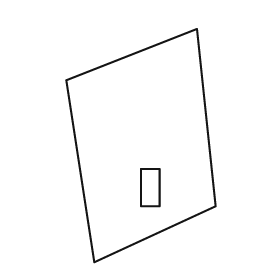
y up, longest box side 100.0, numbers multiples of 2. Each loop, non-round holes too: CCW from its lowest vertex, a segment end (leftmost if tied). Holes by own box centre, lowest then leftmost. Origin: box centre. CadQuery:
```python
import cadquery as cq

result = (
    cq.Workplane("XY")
    .moveTo(-20.0, -50.0)
    .lineTo(32.0, -26.0)
    .lineTo(24.0, 50.0)
    .lineTo(-32.0, 28.0)
    .close()
    .moveTo(0.0, -26.0)
    .lineTo(8.0, -26.0)
    .lineTo(8.0, -10.0)
    .lineTo(0.0, -10.0)
    .close()
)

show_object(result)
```